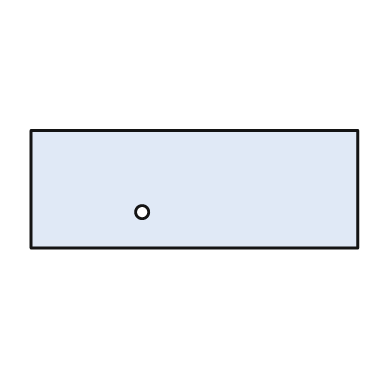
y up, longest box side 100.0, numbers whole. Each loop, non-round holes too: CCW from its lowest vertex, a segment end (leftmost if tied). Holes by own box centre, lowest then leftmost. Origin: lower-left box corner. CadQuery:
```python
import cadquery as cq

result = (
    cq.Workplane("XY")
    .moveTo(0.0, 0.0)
    .lineTo(100.0, 0.0)
    .lineTo(100.0, 36.0)
    .lineTo(0.0, 36.0)
    .close()
    .moveTo(34.0, 11.0)
    .circle(2.0)
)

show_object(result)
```